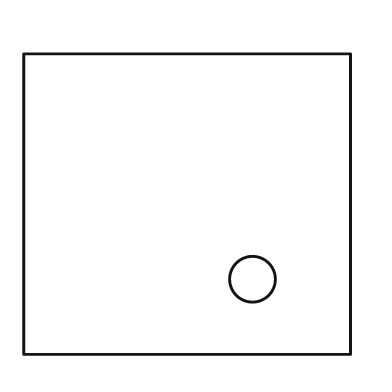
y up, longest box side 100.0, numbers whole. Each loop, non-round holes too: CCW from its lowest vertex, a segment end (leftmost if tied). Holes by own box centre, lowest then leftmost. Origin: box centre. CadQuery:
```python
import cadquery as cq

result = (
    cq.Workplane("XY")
    .moveTo(-50.0, -46.0)
    .lineTo(50.0, -46.0)
    .lineTo(50.0, 46.0)
    .lineTo(-50.0, 46.0)
    .close()
    .moveTo(20.0, -23.0)
    .circle(7.0)
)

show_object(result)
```